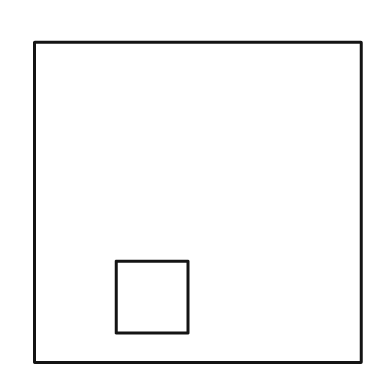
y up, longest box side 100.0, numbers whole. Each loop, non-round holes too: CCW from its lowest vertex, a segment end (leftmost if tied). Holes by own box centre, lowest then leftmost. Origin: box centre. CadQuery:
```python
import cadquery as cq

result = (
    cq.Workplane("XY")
    .moveTo(-50.0, -49.0)
    .lineTo(50.0, -49.0)
    .lineTo(50.0, 49.0)
    .lineTo(-50.0, 49.0)
    .close()
    .moveTo(-25.0, -40.0)
    .lineTo(-3.0, -40.0)
    .lineTo(-3.0, -18.0)
    .lineTo(-25.0, -18.0)
    .close()
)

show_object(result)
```